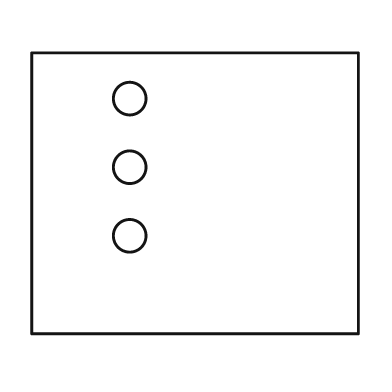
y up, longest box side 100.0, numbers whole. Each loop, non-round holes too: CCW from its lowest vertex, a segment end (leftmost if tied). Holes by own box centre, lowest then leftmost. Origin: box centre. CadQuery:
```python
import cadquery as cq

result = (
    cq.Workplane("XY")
    .moveTo(-50.0, -43.0)
    .lineTo(50.0, -43.0)
    .lineTo(50.0, 43.0)
    .lineTo(-50.0, 43.0)
    .close()
    .moveTo(-20.0, -13.0)
    .circle(5.0)
    .moveTo(-20.0, 8.0)
    .circle(5.0)
    .moveTo(-20.0, 29.0)
    .circle(5.0)
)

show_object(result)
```